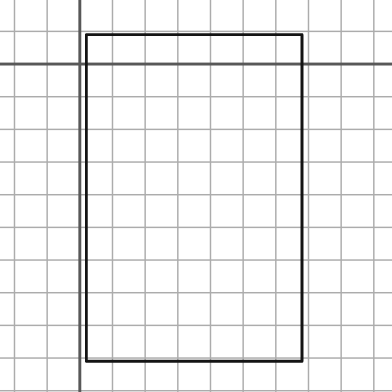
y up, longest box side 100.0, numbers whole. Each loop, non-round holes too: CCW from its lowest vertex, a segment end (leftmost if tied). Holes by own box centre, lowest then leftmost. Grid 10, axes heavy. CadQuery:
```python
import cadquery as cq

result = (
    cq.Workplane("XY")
    .moveTo(2.0, -91.0)
    .lineTo(68.0, -91.0)
    .lineTo(68.0, 9.0)
    .lineTo(2.0, 9.0)
    .close()
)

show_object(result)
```